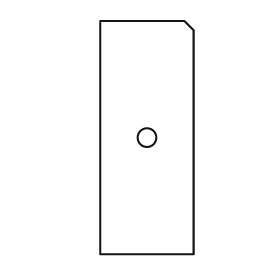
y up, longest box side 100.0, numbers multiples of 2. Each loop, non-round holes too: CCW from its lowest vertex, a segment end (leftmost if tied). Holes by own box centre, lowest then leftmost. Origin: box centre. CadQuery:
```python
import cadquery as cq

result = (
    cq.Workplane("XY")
    .moveTo(-20.0, -50.0)
    .lineTo(20.0, -50.0)
    .lineTo(20.0, 46.0)
    .lineTo(16.0, 50.0)
    .lineTo(-20.0, 50.0)
    .close()
    .moveTo(0.0, 0.0)
    .circle(4.0)
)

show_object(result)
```